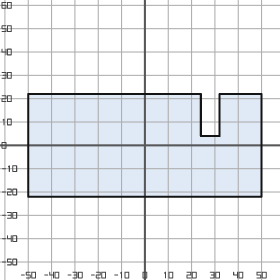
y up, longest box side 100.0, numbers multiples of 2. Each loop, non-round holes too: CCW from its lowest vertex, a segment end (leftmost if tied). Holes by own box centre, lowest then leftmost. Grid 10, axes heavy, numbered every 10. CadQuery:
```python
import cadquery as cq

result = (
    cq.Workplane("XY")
    .moveTo(-50.0, -22.0)
    .lineTo(50.0, -22.0)
    .lineTo(50.0, 22.0)
    .lineTo(32.0, 22.0)
    .lineTo(32.0, 4.0)
    .lineTo(24.0, 4.0)
    .lineTo(24.0, 22.0)
    .lineTo(-50.0, 22.0)
    .close()
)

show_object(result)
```